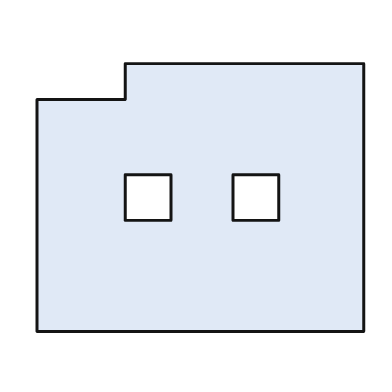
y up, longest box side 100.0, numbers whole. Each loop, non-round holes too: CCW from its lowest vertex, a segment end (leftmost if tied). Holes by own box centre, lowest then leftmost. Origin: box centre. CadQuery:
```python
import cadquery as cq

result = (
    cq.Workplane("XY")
    .moveTo(-50.0, -41.0)
    .lineTo(50.0, -41.0)
    .lineTo(50.0, 41.0)
    .lineTo(-23.0, 41.0)
    .lineTo(-23.0, 30.0)
    .lineTo(-50.0, 30.0)
    .close()
    .moveTo(-23.0, -7.0)
    .lineTo(-9.0, -7.0)
    .lineTo(-9.0, 7.0)
    .lineTo(-23.0, 7.0)
    .close()
    .moveTo(10.0, -7.0)
    .lineTo(24.0, -7.0)
    .lineTo(24.0, 7.0)
    .lineTo(10.0, 7.0)
    .close()
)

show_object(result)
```